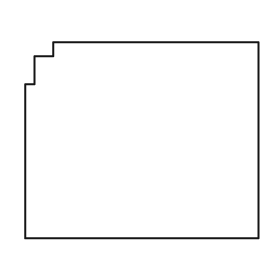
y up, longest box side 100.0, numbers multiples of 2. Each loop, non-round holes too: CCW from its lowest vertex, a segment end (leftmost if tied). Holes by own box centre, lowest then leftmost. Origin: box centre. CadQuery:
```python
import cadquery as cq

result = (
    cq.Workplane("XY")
    .moveTo(-50.0, -42.0)
    .lineTo(50.0, -42.0)
    .lineTo(50.0, 42.0)
    .lineTo(-38.0, 42.0)
    .lineTo(-38.0, 36.0)
    .lineTo(-46.0, 36.0)
    .lineTo(-46.0, 24.0)
    .lineTo(-50.0, 24.0)
    .close()
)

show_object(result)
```